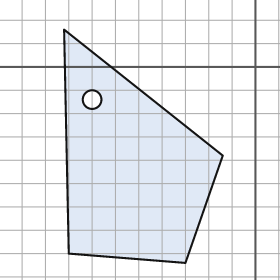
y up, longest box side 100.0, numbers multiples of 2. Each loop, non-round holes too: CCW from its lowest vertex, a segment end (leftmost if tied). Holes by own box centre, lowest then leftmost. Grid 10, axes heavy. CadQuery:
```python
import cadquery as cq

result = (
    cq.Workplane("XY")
    .moveTo(-30.0, -84.0)
    .lineTo(-14.0, -38.0)
    .lineTo(-82.0, 16.0)
    .lineTo(-80.0, -80.0)
    .close()
    .moveTo(-70.0, -14.0)
    .circle(4.0)
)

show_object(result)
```